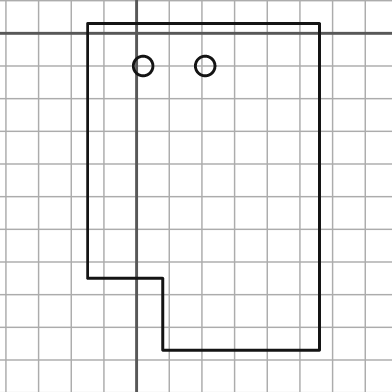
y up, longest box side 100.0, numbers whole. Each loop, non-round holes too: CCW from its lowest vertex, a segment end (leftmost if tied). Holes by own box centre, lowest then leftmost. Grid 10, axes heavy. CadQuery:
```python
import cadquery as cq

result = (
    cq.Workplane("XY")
    .moveTo(8.0, -97.0)
    .lineTo(56.0, -97.0)
    .lineTo(56.0, 3.0)
    .lineTo(-15.0, 3.0)
    .lineTo(-15.0, -75.0)
    .lineTo(8.0, -75.0)
    .close()
    .moveTo(2.0, -10.0)
    .circle(3.0)
    .moveTo(21.0, -10.0)
    .circle(3.0)
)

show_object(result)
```